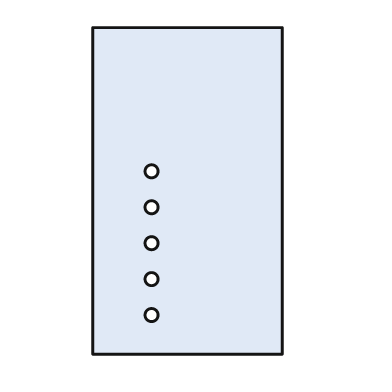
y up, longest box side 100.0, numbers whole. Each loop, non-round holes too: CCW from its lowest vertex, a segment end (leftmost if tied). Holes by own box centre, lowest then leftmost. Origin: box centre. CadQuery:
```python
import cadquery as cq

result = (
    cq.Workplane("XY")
    .moveTo(-29.0, -50.0)
    .lineTo(29.0, -50.0)
    .lineTo(29.0, 50.0)
    .lineTo(-29.0, 50.0)
    .close()
    .moveTo(-11.0, -38.0)
    .circle(2.0)
    .moveTo(-11.0, -27.0)
    .circle(2.0)
    .moveTo(-11.0, -16.0)
    .circle(2.0)
    .moveTo(-11.0, -5.0)
    .circle(2.0)
    .moveTo(-11.0, 6.0)
    .circle(2.0)
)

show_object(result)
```